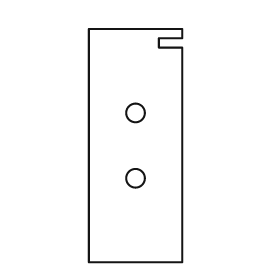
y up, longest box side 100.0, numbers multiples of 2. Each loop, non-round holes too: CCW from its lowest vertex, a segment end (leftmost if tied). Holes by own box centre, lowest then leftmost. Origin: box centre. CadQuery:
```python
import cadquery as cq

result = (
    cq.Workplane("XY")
    .moveTo(-20.0, -50.0)
    .lineTo(20.0, -50.0)
    .lineTo(20.0, 42.0)
    .lineTo(10.0, 42.0)
    .lineTo(10.0, 46.0)
    .lineTo(20.0, 46.0)
    .lineTo(20.0, 50.0)
    .lineTo(-20.0, 50.0)
    .close()
    .moveTo(0.0, -14.0)
    .circle(4.0)
    .moveTo(0.0, 14.0)
    .circle(4.0)
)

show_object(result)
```